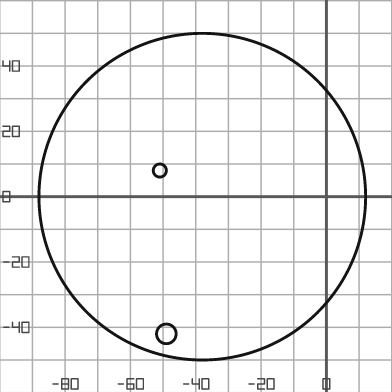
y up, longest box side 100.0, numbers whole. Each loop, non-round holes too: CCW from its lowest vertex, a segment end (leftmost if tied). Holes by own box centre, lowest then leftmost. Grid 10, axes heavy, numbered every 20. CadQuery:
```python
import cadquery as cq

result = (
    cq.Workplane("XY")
    .moveTo(-38.0, 0.0)
    .circle(50.0)
    .moveTo(-49.0, -42.0)
    .circle(3.0)
    .moveTo(-51.0, 8.0)
    .circle(2.0)
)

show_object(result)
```